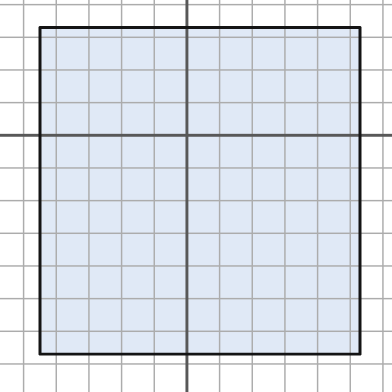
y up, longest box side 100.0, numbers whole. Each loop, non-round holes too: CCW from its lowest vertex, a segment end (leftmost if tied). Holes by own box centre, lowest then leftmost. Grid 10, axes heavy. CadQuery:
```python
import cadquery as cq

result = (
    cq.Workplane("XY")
    .moveTo(-45.0, -67.0)
    .lineTo(53.0, -67.0)
    .lineTo(53.0, 33.0)
    .lineTo(-45.0, 33.0)
    .close()
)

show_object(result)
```